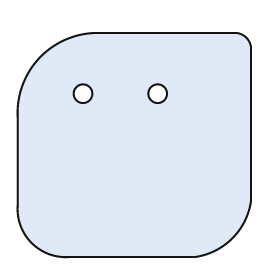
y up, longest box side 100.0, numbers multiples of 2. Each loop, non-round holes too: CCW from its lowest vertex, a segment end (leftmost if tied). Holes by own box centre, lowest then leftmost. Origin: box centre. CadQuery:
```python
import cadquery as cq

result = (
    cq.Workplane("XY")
    .moveTo(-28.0, -48.0)
    .lineTo(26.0, -48.0)
    .threePointArc((42.0, -40.0), (50.0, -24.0))
    .lineTo(50.0, 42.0)
    .threePointArc((48.0, 46.0), (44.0, 48.0))
    .lineTo(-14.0, 48.0)
    .threePointArc((-40.0, 38.0), (-50.0, 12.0))
    .lineTo(-50.0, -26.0)
    .threePointArc((-44.0, -42.0), (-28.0, -48.0))
    .close()
    .moveTo(-22.0, 22.0)
    .circle(4.0)
    .moveTo(10.0, 22.0)
    .circle(4.0)
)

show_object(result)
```